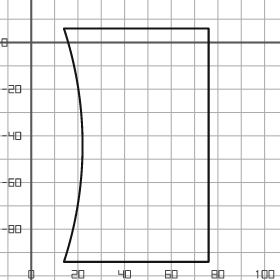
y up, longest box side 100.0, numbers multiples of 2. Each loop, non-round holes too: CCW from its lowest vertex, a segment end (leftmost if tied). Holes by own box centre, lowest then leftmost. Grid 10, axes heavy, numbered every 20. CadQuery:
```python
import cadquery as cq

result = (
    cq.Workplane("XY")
    .moveTo(14.0, -94.0)
    .lineTo(76.0, -94.0)
    .lineTo(76.0, 6.0)
    .lineTo(14.0, 6.0)
    .threePointArc((22.0, -44.0), (14.0, -94.0))
    .close()
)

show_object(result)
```